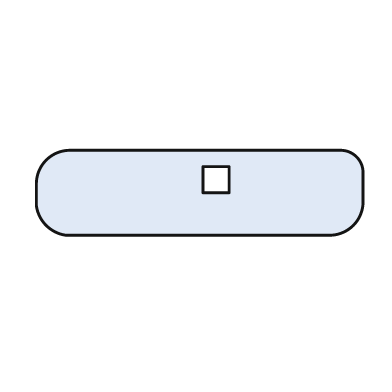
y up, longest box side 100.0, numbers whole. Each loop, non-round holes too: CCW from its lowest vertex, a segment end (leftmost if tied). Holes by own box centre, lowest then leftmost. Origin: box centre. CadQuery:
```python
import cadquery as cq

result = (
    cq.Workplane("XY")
    .moveTo(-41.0, -13.0)
    .lineTo(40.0, -13.0)
    .threePointArc((47.0, -10.0), (50.0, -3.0))
    .lineTo(50.0, 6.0)
    .threePointArc((48.0, 11.0), (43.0, 13.0))
    .lineTo(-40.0, 13.0)
    .threePointArc((-47.0, 10.0), (-50.0, 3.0))
    .lineTo(-50.0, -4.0)
    .threePointArc((-47.0, -10.0), (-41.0, -13.0))
    .close()
    .moveTo(1.0, 0.0)
    .lineTo(9.0, 0.0)
    .lineTo(9.0, 8.0)
    .lineTo(1.0, 8.0)
    .close()
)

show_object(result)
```